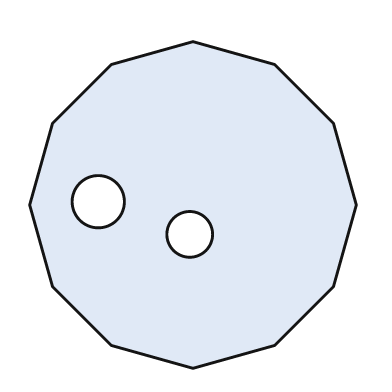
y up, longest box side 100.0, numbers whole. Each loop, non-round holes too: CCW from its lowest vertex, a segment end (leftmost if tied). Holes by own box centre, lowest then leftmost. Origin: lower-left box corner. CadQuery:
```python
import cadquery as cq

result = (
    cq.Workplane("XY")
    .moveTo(50.0, 0.0)
    .lineTo(75.0, 7.0)
    .lineTo(93.0, 25.0)
    .lineTo(100.0, 50.0)
    .lineTo(93.0, 75.0)
    .lineTo(75.0, 93.0)
    .lineTo(50.0, 100.0)
    .lineTo(25.0, 93.0)
    .lineTo(7.0, 75.0)
    .lineTo(0.0, 50.0)
    .lineTo(7.0, 25.0)
    .lineTo(25.0, 7.0)
    .close()
    .moveTo(49.0, 41.0)
    .circle(7.0)
    .moveTo(21.0, 51.0)
    .circle(8.0)
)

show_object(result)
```